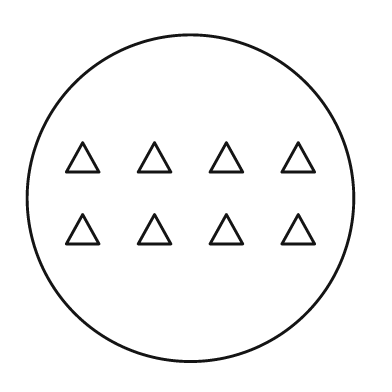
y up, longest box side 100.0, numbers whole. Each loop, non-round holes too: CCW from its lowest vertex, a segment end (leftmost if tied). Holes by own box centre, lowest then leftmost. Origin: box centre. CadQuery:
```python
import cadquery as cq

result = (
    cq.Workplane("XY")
    .moveTo(0.0, 0.0)
    .circle(50.0)
    .moveTo(-38.0, -14.0)
    .lineTo(-28.0, -14.0)
    .lineTo(-33.0, -5.0)
    .close()
    .moveTo(-16.0, -14.0)
    .lineTo(-6.0, -14.0)
    .lineTo(-11.0, -5.0)
    .close()
    .moveTo(6.0, -14.0)
    .lineTo(16.0, -14.0)
    .lineTo(11.0, -5.0)
    .close()
    .moveTo(28.0, -14.0)
    .lineTo(38.0, -14.0)
    .lineTo(33.0, -5.0)
    .close()
    .moveTo(-38.0, 8.0)
    .lineTo(-28.0, 8.0)
    .lineTo(-33.0, 17.0)
    .close()
    .moveTo(-16.0, 8.0)
    .lineTo(-6.0, 8.0)
    .lineTo(-11.0, 17.0)
    .close()
    .moveTo(6.0, 8.0)
    .lineTo(16.0, 8.0)
    .lineTo(11.0, 17.0)
    .close()
    .moveTo(28.0, 8.0)
    .lineTo(38.0, 8.0)
    .lineTo(33.0, 17.0)
    .close()
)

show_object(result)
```